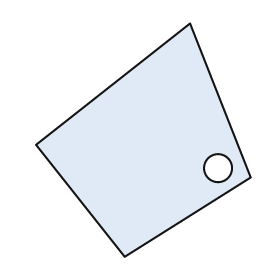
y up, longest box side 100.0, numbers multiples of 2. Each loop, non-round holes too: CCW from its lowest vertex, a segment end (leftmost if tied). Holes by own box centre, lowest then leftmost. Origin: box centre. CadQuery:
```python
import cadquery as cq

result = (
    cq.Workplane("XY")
    .moveTo(-8.0, -50.0)
    .lineTo(46.0, -16.0)
    .lineTo(20.0, 50.0)
    .lineTo(-46.0, -2.0)
    .close()
    .moveTo(32.0, -12.0)
    .circle(6.0)
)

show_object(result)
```